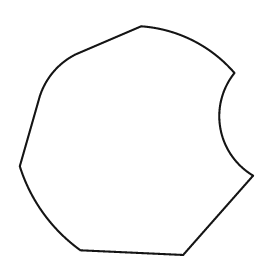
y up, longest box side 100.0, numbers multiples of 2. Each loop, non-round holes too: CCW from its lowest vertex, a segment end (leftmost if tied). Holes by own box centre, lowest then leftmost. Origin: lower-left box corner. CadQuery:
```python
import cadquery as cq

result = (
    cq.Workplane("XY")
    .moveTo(70.0, 0.0)
    .lineTo(100.0, 34.0)
    .threePointArc((86.0, 54.0), (92.0, 78.0))
    .threePointArc((74.0, 92.0), (52.0, 98.0))
    .lineTo(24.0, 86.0)
    .threePointArc((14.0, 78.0), (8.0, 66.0))
    .lineTo(0.0, 38.0)
    .threePointArc((10.0, 18.0), (26.0, 2.0))
    .close()
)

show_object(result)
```